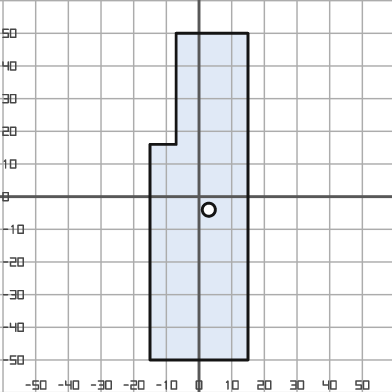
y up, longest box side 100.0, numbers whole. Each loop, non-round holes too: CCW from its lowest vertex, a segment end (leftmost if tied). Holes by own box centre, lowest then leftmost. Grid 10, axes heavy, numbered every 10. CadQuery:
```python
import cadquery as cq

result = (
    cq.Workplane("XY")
    .moveTo(-15.0, -50.0)
    .lineTo(15.0, -50.0)
    .lineTo(15.0, 50.0)
    .lineTo(-7.0, 50.0)
    .lineTo(-7.0, 16.0)
    .lineTo(-15.0, 16.0)
    .close()
    .moveTo(3.0, -4.0)
    .circle(2.0)
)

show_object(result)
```